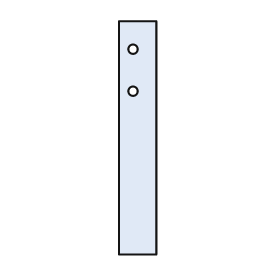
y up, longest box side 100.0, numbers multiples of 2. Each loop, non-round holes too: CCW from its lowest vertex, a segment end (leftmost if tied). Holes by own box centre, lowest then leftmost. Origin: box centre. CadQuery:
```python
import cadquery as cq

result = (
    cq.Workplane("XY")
    .moveTo(-8.0, -50.0)
    .lineTo(8.0, -50.0)
    .lineTo(8.0, 50.0)
    .lineTo(-8.0, 50.0)
    .close()
    .moveTo(-2.0, 20.0)
    .circle(2.0)
    .moveTo(-2.0, 38.0)
    .circle(2.0)
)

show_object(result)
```